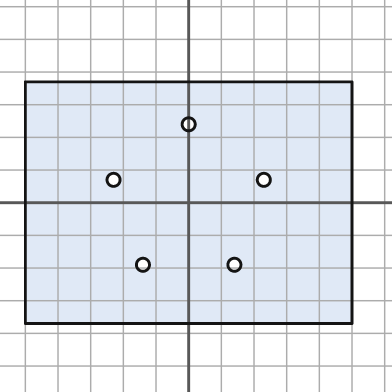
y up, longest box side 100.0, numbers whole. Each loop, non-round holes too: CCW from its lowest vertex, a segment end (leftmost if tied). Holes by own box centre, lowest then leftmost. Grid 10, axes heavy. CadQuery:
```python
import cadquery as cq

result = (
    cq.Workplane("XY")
    .moveTo(-50.0, -37.0)
    .lineTo(50.0, -37.0)
    .lineTo(50.0, 37.0)
    .lineTo(-50.0, 37.0)
    .close()
    .moveTo(-14.0, -19.0)
    .circle(2.0)
    .moveTo(14.0, -19.0)
    .circle(2.0)
    .moveTo(-23.0, 7.0)
    .circle(2.0)
    .moveTo(23.0, 7.0)
    .circle(2.0)
    .moveTo(0.0, 24.0)
    .circle(2.0)
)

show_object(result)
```